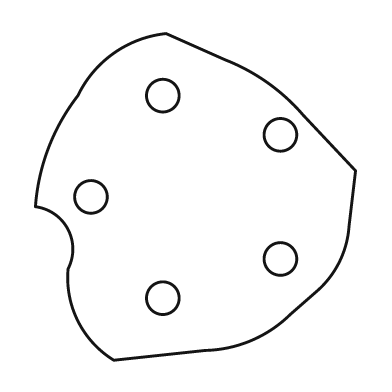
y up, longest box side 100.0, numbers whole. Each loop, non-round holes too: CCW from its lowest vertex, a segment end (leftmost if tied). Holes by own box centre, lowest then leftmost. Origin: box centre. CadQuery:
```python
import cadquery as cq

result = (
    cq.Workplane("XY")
    .moveTo(-25.0, -50.0)
    .lineTo(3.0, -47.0)
    .threePointArc((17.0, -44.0), (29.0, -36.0))
    .lineTo(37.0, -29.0)
    .threePointArc((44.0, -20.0), (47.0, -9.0))
    .lineTo(49.0, 8.0)
    .lineTo(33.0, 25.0)
    .threePointArc((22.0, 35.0), (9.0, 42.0))
    .lineTo(-9.0, 50.0)
    .threePointArc((-25.0, 44.0), (-36.0, 31.0))
    .threePointArc((-45.0, 15.0), (-49.0, -3.0))
    .threePointArc((-39.0, -10.0), (-39.0, -22.0))
    .threePointArc((-36.0, -38.0), (-25.0, -50.0))
    .close()
    .moveTo(-10.0, -31.0)
    .circle(5.0)
    .moveTo(26.0, -19.0)
    .circle(5.0)
    .moveTo(-32.0, 0.0)
    .circle(5.0)
    .moveTo(26.0, 19.0)
    .circle(5.0)
    .moveTo(-10.0, 31.0)
    .circle(5.0)
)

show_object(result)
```